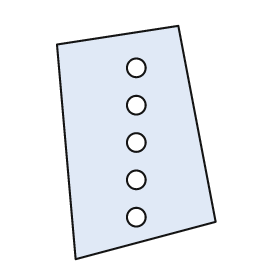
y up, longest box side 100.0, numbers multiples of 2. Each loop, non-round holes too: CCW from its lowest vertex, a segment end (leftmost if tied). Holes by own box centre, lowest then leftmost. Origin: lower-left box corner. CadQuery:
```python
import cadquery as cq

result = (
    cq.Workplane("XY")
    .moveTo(8.0, 0.0)
    .lineTo(68.0, 16.0)
    .lineTo(52.0, 100.0)
    .lineTo(0.0, 92.0)
    .close()
    .moveTo(34.0, 18.0)
    .circle(4.0)
    .moveTo(34.0, 34.0)
    .circle(4.0)
    .moveTo(34.0, 50.0)
    .circle(4.0)
    .moveTo(34.0, 66.0)
    .circle(4.0)
    .moveTo(34.0, 82.0)
    .circle(4.0)
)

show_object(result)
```